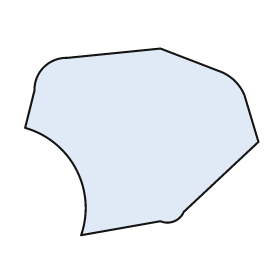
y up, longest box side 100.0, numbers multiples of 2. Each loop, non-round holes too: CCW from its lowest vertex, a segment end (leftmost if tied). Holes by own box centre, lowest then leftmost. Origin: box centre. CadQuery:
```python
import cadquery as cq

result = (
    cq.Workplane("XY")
    .moveTo(-26.0, -40.0)
    .lineTo(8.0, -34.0)
    .threePointArc((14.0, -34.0), (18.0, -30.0))
    .lineTo(50.0, 0.0)
    .lineTo(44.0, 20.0)
    .threePointArc((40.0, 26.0), (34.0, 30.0))
    .lineTo(8.0, 40.0)
    .lineTo(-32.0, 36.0)
    .threePointArc((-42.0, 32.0), (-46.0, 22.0))
    .lineTo(-50.0, 6.0)
    .threePointArc((-28.0, -12.0), (-26.0, -40.0))
    .close()
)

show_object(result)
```